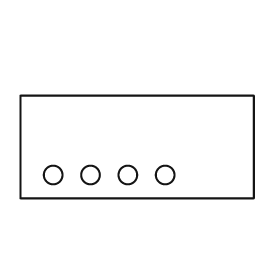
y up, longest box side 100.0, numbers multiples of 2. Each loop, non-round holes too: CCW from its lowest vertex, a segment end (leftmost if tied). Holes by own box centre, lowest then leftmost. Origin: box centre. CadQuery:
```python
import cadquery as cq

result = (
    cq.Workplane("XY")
    .moveTo(-50.0, -22.0)
    .lineTo(50.0, -22.0)
    .lineTo(50.0, 22.0)
    .lineTo(-50.0, 22.0)
    .close()
    .moveTo(-36.0, -12.0)
    .circle(4.0)
    .moveTo(-20.0, -12.0)
    .circle(4.0)
    .moveTo(-4.0, -12.0)
    .circle(4.0)
    .moveTo(12.0, -12.0)
    .circle(4.0)
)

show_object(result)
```